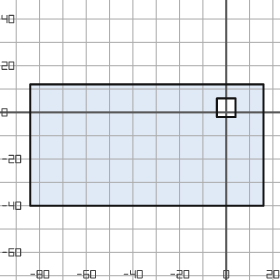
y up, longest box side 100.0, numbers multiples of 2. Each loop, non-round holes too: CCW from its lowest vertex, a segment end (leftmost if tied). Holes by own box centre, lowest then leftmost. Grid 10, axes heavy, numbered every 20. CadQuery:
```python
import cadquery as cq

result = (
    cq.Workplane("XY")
    .moveTo(-84.0, -40.0)
    .lineTo(16.0, -40.0)
    .lineTo(16.0, 12.0)
    .lineTo(-84.0, 12.0)
    .close()
    .moveTo(-4.0, -2.0)
    .lineTo(4.0, -2.0)
    .lineTo(4.0, 6.0)
    .lineTo(-4.0, 6.0)
    .close()
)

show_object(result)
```